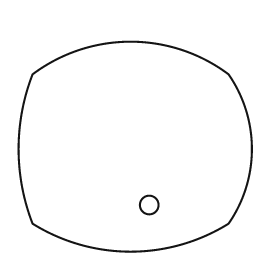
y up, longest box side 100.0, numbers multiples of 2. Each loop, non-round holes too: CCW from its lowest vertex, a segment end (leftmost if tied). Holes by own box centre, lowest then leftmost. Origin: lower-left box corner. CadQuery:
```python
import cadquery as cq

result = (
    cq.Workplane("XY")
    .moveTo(6.0, 12.0)
    .threePointArc((48.0, 0.0), (90.0, 12.0))
    .threePointArc((100.0, 44.0), (90.0, 76.0))
    .threePointArc((48.0, 90.0), (6.0, 76.0))
    .threePointArc((0.0, 44.0), (6.0, 12.0))
    .close()
    .moveTo(56.0, 20.0)
    .circle(4.0)
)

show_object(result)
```